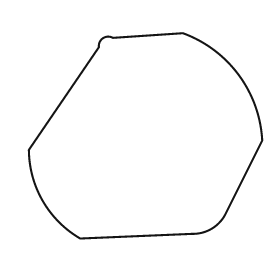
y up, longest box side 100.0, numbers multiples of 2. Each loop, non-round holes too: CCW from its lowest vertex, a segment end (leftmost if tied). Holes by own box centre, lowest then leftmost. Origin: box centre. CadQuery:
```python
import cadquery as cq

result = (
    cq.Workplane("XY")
    .moveTo(-28.0, -44.0)
    .lineTo(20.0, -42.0)
    .threePointArc((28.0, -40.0), (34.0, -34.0))
    .lineTo(50.0, -2.0)
    .threePointArc((40.0, 26.0), (16.0, 44.0))
    .lineTo(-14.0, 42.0)
    .threePointArc((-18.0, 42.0), (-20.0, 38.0))
    .lineTo(-50.0, -6.0)
    .threePointArc((-44.0, -28.0), (-28.0, -44.0))
    .close()
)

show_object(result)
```